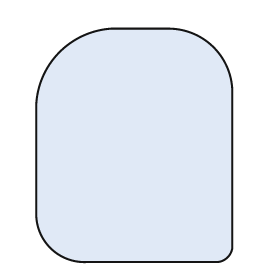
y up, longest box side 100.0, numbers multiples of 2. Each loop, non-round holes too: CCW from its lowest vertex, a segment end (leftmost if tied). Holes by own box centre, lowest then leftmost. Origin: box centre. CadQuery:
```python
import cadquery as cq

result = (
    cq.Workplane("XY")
    .moveTo(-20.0, -50.0)
    .lineTo(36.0, -50.0)
    .threePointArc((40.0, -48.0), (42.0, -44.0))
    .lineTo(42.0, 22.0)
    .threePointArc((34.0, 42.0), (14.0, 50.0))
    .lineTo(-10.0, 50.0)
    .threePointArc((-32.0, 40.0), (-42.0, 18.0))
    .lineTo(-42.0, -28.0)
    .threePointArc((-36.0, -44.0), (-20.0, -50.0))
    .close()
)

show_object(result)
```